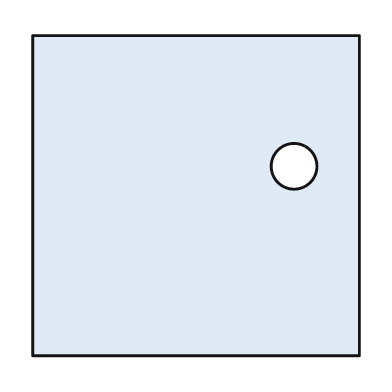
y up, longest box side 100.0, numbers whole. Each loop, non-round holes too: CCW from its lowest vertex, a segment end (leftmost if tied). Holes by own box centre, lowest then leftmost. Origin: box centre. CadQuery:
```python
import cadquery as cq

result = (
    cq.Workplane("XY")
    .moveTo(-50.0, -49.0)
    .lineTo(50.0, -49.0)
    .lineTo(50.0, 49.0)
    .lineTo(-50.0, 49.0)
    .close()
    .moveTo(30.0, 9.0)
    .circle(7.0)
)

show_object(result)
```